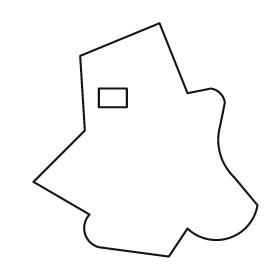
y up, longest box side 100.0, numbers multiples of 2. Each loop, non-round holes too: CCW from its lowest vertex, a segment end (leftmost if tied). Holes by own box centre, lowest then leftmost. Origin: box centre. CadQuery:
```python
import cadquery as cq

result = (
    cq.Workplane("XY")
    .moveTo(10.0, -50.0)
    .lineTo(18.0, -38.0)
    .threePointArc((36.0, -42.0), (48.0, -28.0))
    .lineTo(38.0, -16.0)
    .threePointArc((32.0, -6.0), (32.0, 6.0))
    .lineTo(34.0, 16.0)
    .threePointArc((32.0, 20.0), (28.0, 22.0))
    .lineTo(18.0, 20.0)
    .lineTo(6.0, 50.0)
    .lineTo(-28.0, 36.0)
    .lineTo(-26.0, 4.0)
    .lineTo(-48.0, -18.0)
    .lineTo(-24.0, -32.0)
    .threePointArc((-26.0, -40.0), (-20.0, -46.0))
    .close()
    .moveTo(-20.0, 14.0)
    .lineTo(-8.0, 14.0)
    .lineTo(-8.0, 22.0)
    .lineTo(-20.0, 22.0)
    .close()
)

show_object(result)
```